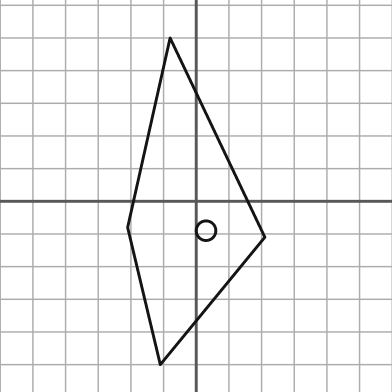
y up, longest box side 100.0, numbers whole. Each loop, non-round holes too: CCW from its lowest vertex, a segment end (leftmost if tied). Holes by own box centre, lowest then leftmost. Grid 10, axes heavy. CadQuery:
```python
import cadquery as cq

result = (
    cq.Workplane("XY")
    .moveTo(-11.0, -50.0)
    .lineTo(21.0, -11.0)
    .lineTo(-8.0, 50.0)
    .lineTo(-21.0, -8.0)
    .close()
    .moveTo(3.0, -9.0)
    .circle(3.0)
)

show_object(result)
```